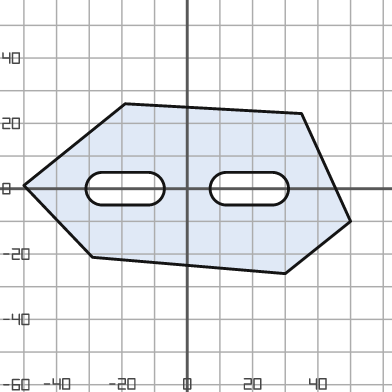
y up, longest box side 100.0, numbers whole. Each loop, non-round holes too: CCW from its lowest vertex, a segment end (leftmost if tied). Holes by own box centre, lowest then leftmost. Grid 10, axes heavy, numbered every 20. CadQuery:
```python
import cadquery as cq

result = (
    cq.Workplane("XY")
    .moveTo(30.0, -26.0)
    .lineTo(50.0, -10.0)
    .lineTo(35.0, 23.0)
    .lineTo(-19.0, 26.0)
    .lineTo(-50.0, 1.0)
    .lineTo(-29.0, -21.0)
    .close()
    .moveTo(-26.0, -5.0)
    .lineTo(-12.0, -5.0)
    .threePointArc((-7.0, 0.0), (-12.0, 5.0))
    .lineTo(-26.0, 5.0)
    .threePointArc((-31.0, 0.0), (-26.0, -5.0))
    .close()
    .moveTo(12.0, -5.0)
    .lineTo(26.0, -5.0)
    .threePointArc((31.0, 0.0), (26.0, 5.0))
    .lineTo(12.0, 5.0)
    .threePointArc((7.0, 0.0), (12.0, -5.0))
    .close()
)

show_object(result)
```